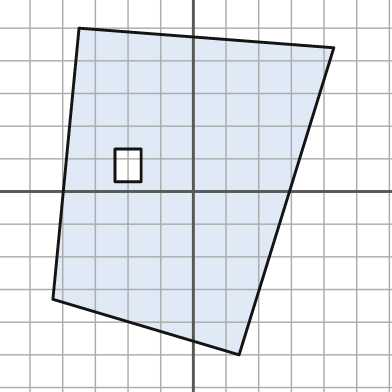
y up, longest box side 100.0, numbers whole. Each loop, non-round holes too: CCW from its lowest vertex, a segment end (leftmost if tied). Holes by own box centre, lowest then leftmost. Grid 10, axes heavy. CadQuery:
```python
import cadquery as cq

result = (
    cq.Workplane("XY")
    .moveTo(14.0, -50.0)
    .lineTo(43.0, 44.0)
    .lineTo(-35.0, 50.0)
    .lineTo(-43.0, -33.0)
    .close()
    .moveTo(-24.0, 3.0)
    .lineTo(-16.0, 3.0)
    .lineTo(-16.0, 13.0)
    .lineTo(-24.0, 13.0)
    .close()
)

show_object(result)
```